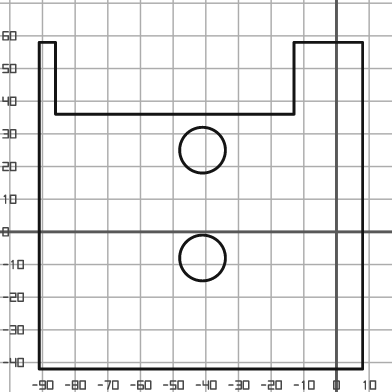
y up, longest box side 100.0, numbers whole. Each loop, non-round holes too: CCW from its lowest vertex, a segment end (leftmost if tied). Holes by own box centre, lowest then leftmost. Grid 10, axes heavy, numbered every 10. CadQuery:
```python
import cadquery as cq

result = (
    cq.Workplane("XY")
    .moveTo(-91.0, -42.0)
    .lineTo(8.0, -42.0)
    .lineTo(8.0, 58.0)
    .lineTo(-13.0, 58.0)
    .lineTo(-13.0, 36.0)
    .lineTo(-86.0, 36.0)
    .lineTo(-86.0, 58.0)
    .lineTo(-91.0, 58.0)
    .close()
    .moveTo(-41.0, -8.0)
    .circle(7.0)
    .moveTo(-41.0, 25.0)
    .circle(7.0)
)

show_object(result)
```